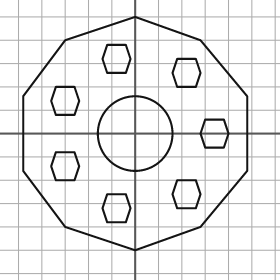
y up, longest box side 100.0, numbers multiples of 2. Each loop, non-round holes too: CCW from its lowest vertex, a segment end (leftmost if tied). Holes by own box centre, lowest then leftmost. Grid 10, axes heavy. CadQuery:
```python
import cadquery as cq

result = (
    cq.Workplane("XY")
    .moveTo(0.0, -50.0)
    .lineTo(28.0, -40.0)
    .lineTo(48.0, -16.0)
    .lineTo(48.0, 16.0)
    .lineTo(28.0, 40.0)
    .lineTo(0.0, 50.0)
    .lineTo(-30.0, 40.0)
    .lineTo(-48.0, 16.0)
    .lineTo(-48.0, -16.0)
    .lineTo(-30.0, -40.0)
    .close()
    .moveTo(-12.0, -38.0)
    .lineTo(-4.0, -38.0)
    .lineTo(-2.0, -32.0)
    .lineTo(-4.0, -26.0)
    .lineTo(-12.0, -26.0)
    .lineTo(-14.0, -32.0)
    .close()
    .moveTo(18.0, -32.0)
    .lineTo(26.0, -32.0)
    .lineTo(28.0, -26.0)
    .lineTo(26.0, -20.0)
    .lineTo(18.0, -20.0)
    .lineTo(16.0, -26.0)
    .close()
    .moveTo(-34.0, -20.0)
    .lineTo(-26.0, -20.0)
    .lineTo(-24.0, -14.0)
    .lineTo(-26.0, -8.0)
    .lineTo(-34.0, -8.0)
    .lineTo(-36.0, -14.0)
    .close()
    .moveTo(0.0, 0.0)
    .circle(16.0)
    .moveTo(30.0, -6.0)
    .lineTo(38.0, -6.0)
    .lineTo(40.0, 0.0)
    .lineTo(38.0, 6.0)
    .lineTo(30.0, 6.0)
    .lineTo(28.0, 0.0)
    .close()
    .moveTo(-34.0, 8.0)
    .lineTo(-26.0, 8.0)
    .lineTo(-24.0, 14.0)
    .lineTo(-26.0, 20.0)
    .lineTo(-34.0, 20.0)
    .lineTo(-36.0, 14.0)
    .close()
    .moveTo(18.0, 20.0)
    .lineTo(26.0, 20.0)
    .lineTo(28.0, 26.0)
    .lineTo(26.0, 32.0)
    .lineTo(18.0, 32.0)
    .lineTo(16.0, 26.0)
    .close()
    .moveTo(-12.0, 26.0)
    .lineTo(-4.0, 26.0)
    .lineTo(-2.0, 32.0)
    .lineTo(-4.0, 38.0)
    .lineTo(-12.0, 38.0)
    .lineTo(-14.0, 32.0)
    .close()
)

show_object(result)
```